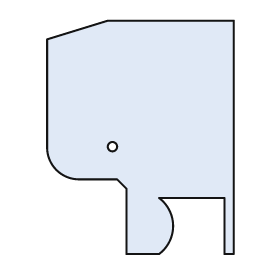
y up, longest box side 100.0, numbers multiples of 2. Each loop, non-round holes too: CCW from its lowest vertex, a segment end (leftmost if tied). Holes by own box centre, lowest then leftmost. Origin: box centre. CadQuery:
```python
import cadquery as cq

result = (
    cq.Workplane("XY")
    .moveTo(-6.0, -50.0)
    .lineTo(8.0, -50.0)
    .threePointArc((14.0, -38.0), (8.0, -26.0))
    .lineTo(36.0, -26.0)
    .lineTo(36.0, -50.0)
    .lineTo(40.0, -50.0)
    .lineTo(40.0, 50.0)
    .lineTo(-14.0, 50.0)
    .lineTo(-40.0, 42.0)
    .lineTo(-40.0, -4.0)
    .threePointArc((-36.0, -14.0), (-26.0, -18.0))
    .lineTo(-10.0, -18.0)
    .lineTo(-6.0, -22.0)
    .close()
    .moveTo(-12.0, -4.0)
    .circle(2.0)
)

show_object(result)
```